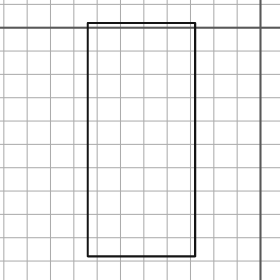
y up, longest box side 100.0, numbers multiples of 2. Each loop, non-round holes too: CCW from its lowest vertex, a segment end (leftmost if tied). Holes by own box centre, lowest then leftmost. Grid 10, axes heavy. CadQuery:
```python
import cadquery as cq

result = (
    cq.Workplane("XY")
    .moveTo(-74.0, -98.0)
    .lineTo(-28.0, -98.0)
    .lineTo(-28.0, 2.0)
    .lineTo(-74.0, 2.0)
    .close()
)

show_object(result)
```